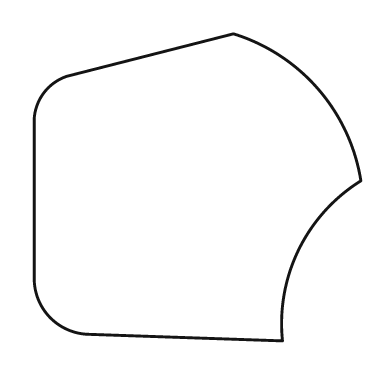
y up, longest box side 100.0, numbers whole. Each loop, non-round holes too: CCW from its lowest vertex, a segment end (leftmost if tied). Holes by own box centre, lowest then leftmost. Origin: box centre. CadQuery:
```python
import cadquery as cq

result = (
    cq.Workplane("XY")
    .moveTo(26.0, -47.0)
    .threePointArc((31.0, -19.0), (50.0, 2.0))
    .threePointArc((37.0, 30.0), (11.0, 47.0))
    .lineTo(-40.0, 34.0)
    .threePointArc((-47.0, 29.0), (-50.0, 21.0))
    .lineTo(-50.0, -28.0)
    .threePointArc((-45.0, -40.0), (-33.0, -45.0))
    .close()
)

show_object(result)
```